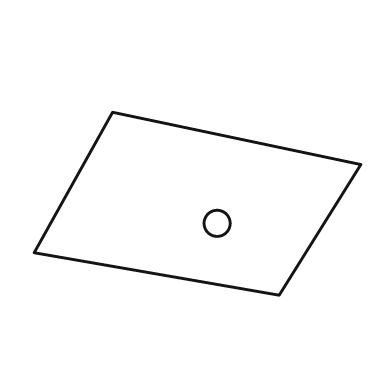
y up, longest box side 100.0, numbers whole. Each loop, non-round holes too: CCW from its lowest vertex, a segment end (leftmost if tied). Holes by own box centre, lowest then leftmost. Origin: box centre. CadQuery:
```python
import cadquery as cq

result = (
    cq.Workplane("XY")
    .moveTo(25.0, -28.0)
    .lineTo(50.0, 12.0)
    .lineTo(-26.0, 28.0)
    .lineTo(-50.0, -15.0)
    .close()
    .moveTo(6.0, -6.0)
    .circle(4.0)
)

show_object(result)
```